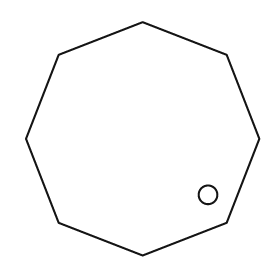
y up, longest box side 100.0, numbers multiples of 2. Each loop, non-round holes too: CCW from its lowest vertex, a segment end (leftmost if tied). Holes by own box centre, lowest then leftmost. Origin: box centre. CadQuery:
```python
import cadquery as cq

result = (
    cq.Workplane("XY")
    .moveTo(0.0, -50.0)
    .lineTo(36.0, -36.0)
    .lineTo(50.0, 0.0)
    .lineTo(36.0, 36.0)
    .lineTo(0.0, 50.0)
    .lineTo(-36.0, 36.0)
    .lineTo(-50.0, 0.0)
    .lineTo(-36.0, -36.0)
    .close()
    .moveTo(28.0, -24.0)
    .circle(4.0)
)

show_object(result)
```